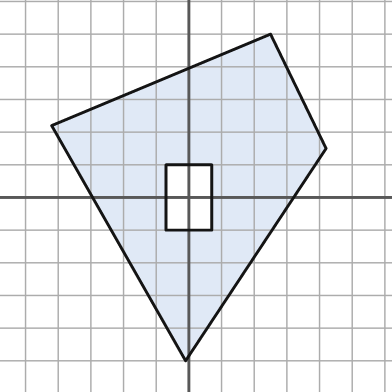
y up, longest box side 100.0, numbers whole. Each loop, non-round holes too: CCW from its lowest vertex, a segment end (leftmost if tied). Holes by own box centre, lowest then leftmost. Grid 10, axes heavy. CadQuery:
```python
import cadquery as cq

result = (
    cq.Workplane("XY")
    .moveTo(-1.0, -50.0)
    .lineTo(42.0, 15.0)
    .lineTo(25.0, 50.0)
    .lineTo(-42.0, 22.0)
    .close()
    .moveTo(-7.0, -10.0)
    .lineTo(7.0, -10.0)
    .lineTo(7.0, 10.0)
    .lineTo(-7.0, 10.0)
    .close()
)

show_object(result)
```